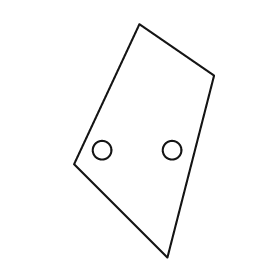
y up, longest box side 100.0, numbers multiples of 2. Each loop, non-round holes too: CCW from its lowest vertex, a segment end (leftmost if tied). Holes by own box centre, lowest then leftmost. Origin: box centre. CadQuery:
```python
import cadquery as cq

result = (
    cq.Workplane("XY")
    .moveTo(10.0, -50.0)
    .lineTo(30.0, 28.0)
    .lineTo(-2.0, 50.0)
    .lineTo(-30.0, -10.0)
    .close()
    .moveTo(-18.0, -4.0)
    .circle(4.0)
    .moveTo(12.0, -4.0)
    .circle(4.0)
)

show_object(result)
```